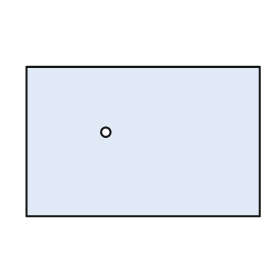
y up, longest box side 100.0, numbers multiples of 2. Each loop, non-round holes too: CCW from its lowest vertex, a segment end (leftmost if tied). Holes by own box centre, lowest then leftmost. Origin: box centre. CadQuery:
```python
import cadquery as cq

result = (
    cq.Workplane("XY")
    .moveTo(-50.0, -32.0)
    .lineTo(50.0, -32.0)
    .lineTo(50.0, 32.0)
    .lineTo(-50.0, 32.0)
    .close()
    .moveTo(-16.0, 4.0)
    .circle(2.0)
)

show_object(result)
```